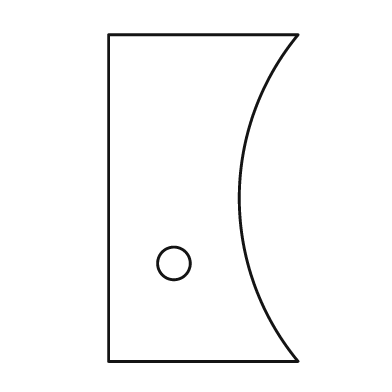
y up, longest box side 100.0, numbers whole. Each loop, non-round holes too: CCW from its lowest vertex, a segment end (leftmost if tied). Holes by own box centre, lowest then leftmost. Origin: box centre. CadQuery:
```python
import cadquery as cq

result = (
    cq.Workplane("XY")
    .moveTo(-29.0, -50.0)
    .lineTo(29.0, -50.0)
    .threePointArc((11.0, 0.0), (29.0, 50.0))
    .lineTo(-29.0, 50.0)
    .close()
    .moveTo(-9.0, -20.0)
    .circle(5.0)
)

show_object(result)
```